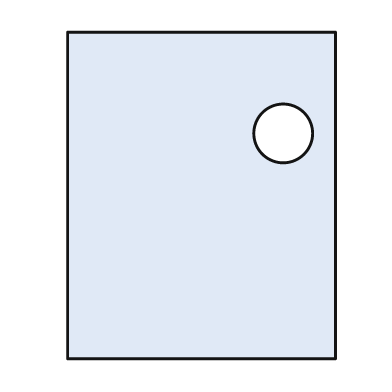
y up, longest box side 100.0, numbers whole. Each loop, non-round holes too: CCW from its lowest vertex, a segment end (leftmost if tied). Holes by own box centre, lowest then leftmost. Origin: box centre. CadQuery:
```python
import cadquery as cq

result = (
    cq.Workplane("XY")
    .moveTo(-41.0, -50.0)
    .lineTo(41.0, -50.0)
    .lineTo(41.0, 50.0)
    .lineTo(-41.0, 50.0)
    .close()
    .moveTo(25.0, 19.0)
    .circle(9.0)
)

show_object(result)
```